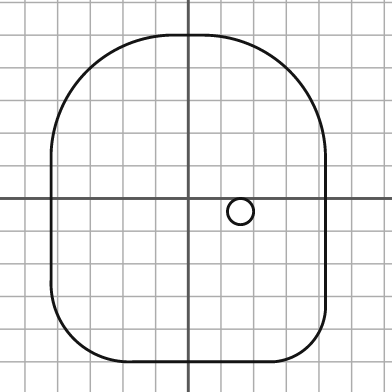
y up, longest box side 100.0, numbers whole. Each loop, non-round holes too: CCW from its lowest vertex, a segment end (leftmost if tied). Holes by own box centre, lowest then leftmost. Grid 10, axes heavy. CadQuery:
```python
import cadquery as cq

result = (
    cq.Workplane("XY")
    .moveTo(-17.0, -50.0)
    .lineTo(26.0, -50.0)
    .threePointArc((37.0, -45.0), (42.0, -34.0))
    .lineTo(42.0, 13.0)
    .threePointArc((31.0, 39.0), (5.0, 50.0))
    .lineTo(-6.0, 50.0)
    .threePointArc((-31.0, 39.0), (-42.0, 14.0))
    .lineTo(-42.0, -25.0)
    .threePointArc((-35.0, -43.0), (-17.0, -50.0))
    .close()
    .moveTo(16.0, -4.0)
    .circle(4.0)
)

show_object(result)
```